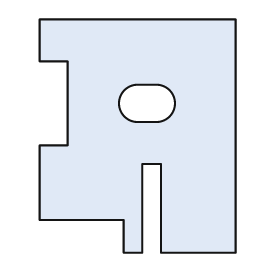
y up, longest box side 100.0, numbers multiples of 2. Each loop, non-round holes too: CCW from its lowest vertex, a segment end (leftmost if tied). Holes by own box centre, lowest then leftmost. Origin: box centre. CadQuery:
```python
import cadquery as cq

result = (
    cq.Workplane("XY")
    .moveTo(-6.0, -50.0)
    .lineTo(2.0, -50.0)
    .lineTo(2.0, -12.0)
    .lineTo(10.0, -12.0)
    .lineTo(10.0, -50.0)
    .lineTo(42.0, -50.0)
    .lineTo(42.0, 50.0)
    .lineTo(-42.0, 50.0)
    .lineTo(-42.0, 32.0)
    .lineTo(-30.0, 32.0)
    .lineTo(-30.0, -4.0)
    .lineTo(-42.0, -4.0)
    .lineTo(-42.0, -36.0)
    .lineTo(-6.0, -36.0)
    .close()
    .moveTo(0.0, 6.0)
    .lineTo(8.0, 6.0)
    .threePointArc((16.0, 14.0), (8.0, 22.0))
    .lineTo(0.0, 22.0)
    .threePointArc((-8.0, 14.0), (0.0, 6.0))
    .close()
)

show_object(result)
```